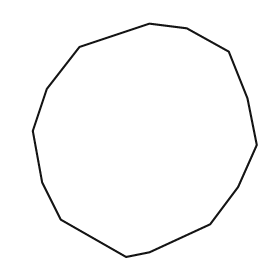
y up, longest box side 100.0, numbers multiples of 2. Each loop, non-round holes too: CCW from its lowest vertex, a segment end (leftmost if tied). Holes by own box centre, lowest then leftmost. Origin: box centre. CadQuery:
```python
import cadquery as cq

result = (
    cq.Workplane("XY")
    .moveTo(-8.0, -50.0)
    .lineTo(2.0, -48.0)
    .lineTo(28.0, -36.0)
    .lineTo(40.0, -20.0)
    .lineTo(48.0, -2.0)
    .lineTo(44.0, 18.0)
    .lineTo(36.0, 38.0)
    .lineTo(18.0, 48.0)
    .lineTo(2.0, 50.0)
    .lineTo(-28.0, 40.0)
    .lineTo(-42.0, 22.0)
    .lineTo(-48.0, 4.0)
    .lineTo(-44.0, -18.0)
    .lineTo(-36.0, -34.0)
    .close()
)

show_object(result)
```